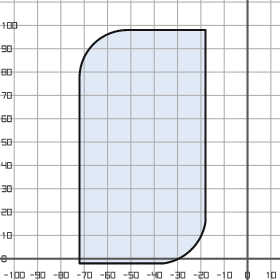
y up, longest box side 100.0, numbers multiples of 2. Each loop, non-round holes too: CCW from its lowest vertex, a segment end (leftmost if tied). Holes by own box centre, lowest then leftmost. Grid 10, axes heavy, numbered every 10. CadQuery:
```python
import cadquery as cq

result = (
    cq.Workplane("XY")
    .moveTo(-72.0, -2.0)
    .lineTo(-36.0, -2.0)
    .threePointArc((-24.0, 4.0), (-18.0, 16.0))
    .lineTo(-18.0, 98.0)
    .lineTo(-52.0, 98.0)
    .threePointArc((-66.0, 92.0), (-72.0, 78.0))
    .close()
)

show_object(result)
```